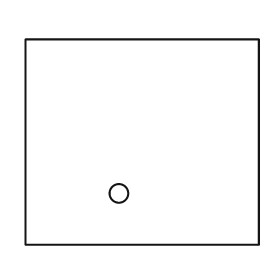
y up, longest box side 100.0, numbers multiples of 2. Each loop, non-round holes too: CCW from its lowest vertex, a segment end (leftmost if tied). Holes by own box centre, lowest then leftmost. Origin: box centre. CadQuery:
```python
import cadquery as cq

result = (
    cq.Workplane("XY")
    .moveTo(-50.0, -44.0)
    .lineTo(50.0, -44.0)
    .lineTo(50.0, 44.0)
    .lineTo(-50.0, 44.0)
    .close()
    .moveTo(-10.0, -22.0)
    .circle(4.0)
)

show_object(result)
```